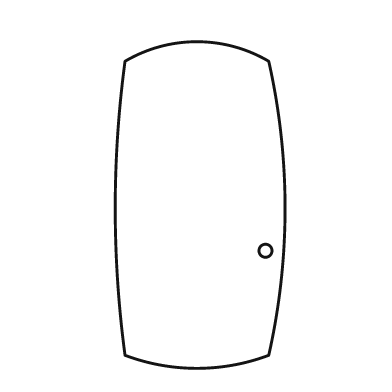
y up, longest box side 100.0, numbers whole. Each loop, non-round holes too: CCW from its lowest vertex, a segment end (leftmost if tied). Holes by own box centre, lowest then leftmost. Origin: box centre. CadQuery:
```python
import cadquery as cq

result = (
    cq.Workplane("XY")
    .moveTo(-23.0, -46.0)
    .threePointArc((-1.0, -50.0), (21.0, -46.0))
    .threePointArc((26.0, -1.0), (21.0, 44.0))
    .threePointArc((-1.0, 50.0), (-23.0, 44.0))
    .threePointArc((-26.0, -1.0), (-23.0, -46.0))
    .close()
    .moveTo(20.0, -14.0)
    .circle(2.0)
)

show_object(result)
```